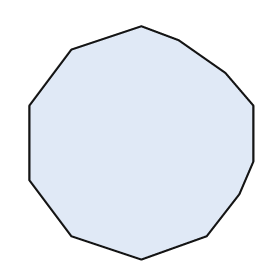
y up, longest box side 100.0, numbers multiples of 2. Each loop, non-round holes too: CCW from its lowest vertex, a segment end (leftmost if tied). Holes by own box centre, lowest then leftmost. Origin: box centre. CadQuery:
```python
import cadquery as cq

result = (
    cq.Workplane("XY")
    .moveTo(0.0, -50.0)
    .lineTo(28.0, -40.0)
    .lineTo(42.0, -22.0)
    .lineTo(48.0, -8.0)
    .lineTo(48.0, 16.0)
    .lineTo(36.0, 30.0)
    .lineTo(16.0, 44.0)
    .lineTo(0.0, 50.0)
    .lineTo(-30.0, 40.0)
    .lineTo(-48.0, 16.0)
    .lineTo(-48.0, -16.0)
    .lineTo(-30.0, -40.0)
    .close()
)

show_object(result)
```